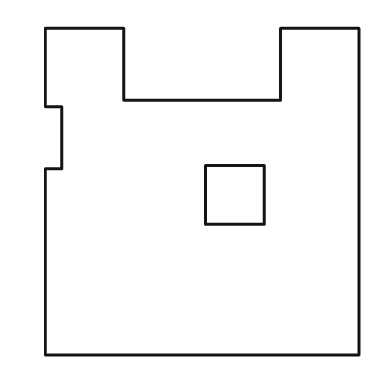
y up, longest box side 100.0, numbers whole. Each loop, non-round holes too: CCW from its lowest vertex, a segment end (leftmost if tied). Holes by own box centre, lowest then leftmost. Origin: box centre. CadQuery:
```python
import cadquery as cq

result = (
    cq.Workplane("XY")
    .moveTo(-48.0, -50.0)
    .lineTo(48.0, -50.0)
    .lineTo(48.0, 50.0)
    .lineTo(24.0, 50.0)
    .lineTo(24.0, 28.0)
    .lineTo(-24.0, 28.0)
    .lineTo(-24.0, 50.0)
    .lineTo(-48.0, 50.0)
    .lineTo(-48.0, 26.0)
    .lineTo(-43.0, 26.0)
    .lineTo(-43.0, 7.0)
    .lineTo(-48.0, 7.0)
    .close()
    .moveTo(1.0, -10.0)
    .lineTo(19.0, -10.0)
    .lineTo(19.0, 8.0)
    .lineTo(1.0, 8.0)
    .close()
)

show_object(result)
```